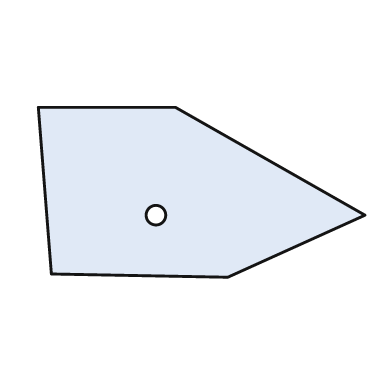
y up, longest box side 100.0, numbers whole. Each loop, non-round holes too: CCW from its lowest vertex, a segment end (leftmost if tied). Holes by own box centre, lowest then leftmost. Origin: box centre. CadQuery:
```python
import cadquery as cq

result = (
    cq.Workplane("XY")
    .moveTo(8.0, -26.0)
    .lineTo(50.0, -7.0)
    .lineTo(-8.0, 26.0)
    .lineTo(-50.0, 26.0)
    .lineTo(-46.0, -25.0)
    .close()
    .moveTo(-14.0, -7.0)
    .circle(3.0)
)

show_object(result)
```